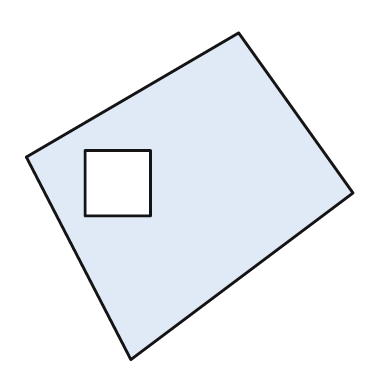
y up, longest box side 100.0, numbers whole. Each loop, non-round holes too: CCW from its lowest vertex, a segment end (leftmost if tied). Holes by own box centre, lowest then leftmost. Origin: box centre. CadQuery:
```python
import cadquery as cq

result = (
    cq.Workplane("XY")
    .moveTo(-18.0, -50.0)
    .lineTo(50.0, 1.0)
    .lineTo(15.0, 50.0)
    .lineTo(-50.0, 12.0)
    .close()
    .moveTo(-32.0, -6.0)
    .lineTo(-12.0, -6.0)
    .lineTo(-12.0, 14.0)
    .lineTo(-32.0, 14.0)
    .close()
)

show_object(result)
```